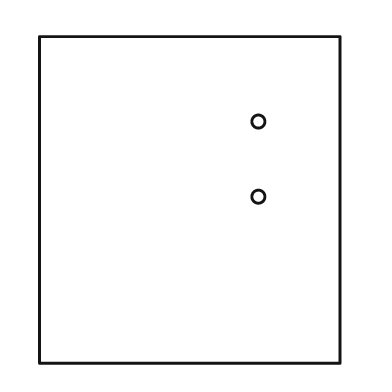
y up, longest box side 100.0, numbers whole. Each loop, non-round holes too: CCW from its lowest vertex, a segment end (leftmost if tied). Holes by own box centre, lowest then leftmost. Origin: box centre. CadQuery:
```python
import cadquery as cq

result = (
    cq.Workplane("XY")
    .moveTo(-46.0, -50.0)
    .lineTo(46.0, -50.0)
    .lineTo(46.0, 50.0)
    .lineTo(-46.0, 50.0)
    .close()
    .moveTo(21.0, 1.0)
    .circle(2.0)
    .moveTo(21.0, 24.0)
    .circle(2.0)
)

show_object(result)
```